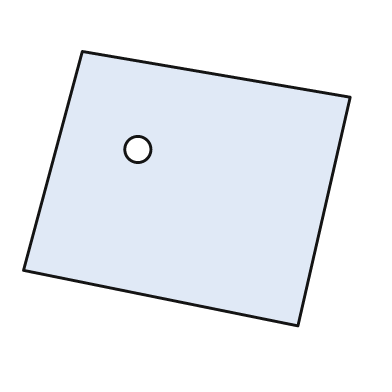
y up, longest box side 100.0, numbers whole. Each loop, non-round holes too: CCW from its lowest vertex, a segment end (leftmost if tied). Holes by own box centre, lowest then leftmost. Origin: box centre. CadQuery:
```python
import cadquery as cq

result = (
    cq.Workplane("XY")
    .moveTo(34.0, -42.0)
    .lineTo(50.0, 28.0)
    .lineTo(-32.0, 42.0)
    .lineTo(-50.0, -25.0)
    .close()
    .moveTo(-15.0, 12.0)
    .circle(4.0)
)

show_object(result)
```